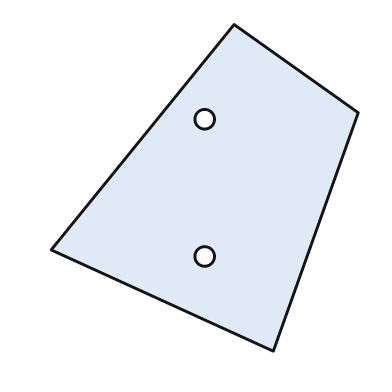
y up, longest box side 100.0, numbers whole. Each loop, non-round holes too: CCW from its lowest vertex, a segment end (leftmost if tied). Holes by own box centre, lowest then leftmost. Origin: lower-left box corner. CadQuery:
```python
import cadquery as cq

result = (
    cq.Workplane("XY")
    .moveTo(68.0, 0.0)
    .lineTo(94.0, 73.0)
    .lineTo(56.0, 100.0)
    .lineTo(0.0, 31.0)
    .close()
    .moveTo(47.0, 29.0)
    .circle(3.0)
    .moveTo(47.0, 71.0)
    .circle(3.0)
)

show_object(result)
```